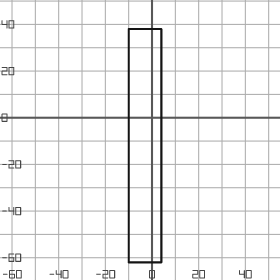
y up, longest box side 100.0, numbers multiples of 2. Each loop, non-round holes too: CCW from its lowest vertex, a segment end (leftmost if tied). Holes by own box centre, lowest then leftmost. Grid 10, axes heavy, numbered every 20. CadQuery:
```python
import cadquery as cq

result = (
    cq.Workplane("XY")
    .moveTo(-10.0, -62.0)
    .lineTo(4.0, -62.0)
    .lineTo(4.0, 38.0)
    .lineTo(-10.0, 38.0)
    .close()
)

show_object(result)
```